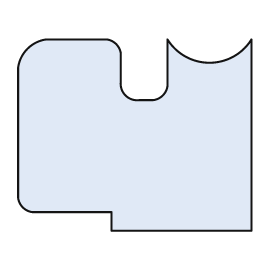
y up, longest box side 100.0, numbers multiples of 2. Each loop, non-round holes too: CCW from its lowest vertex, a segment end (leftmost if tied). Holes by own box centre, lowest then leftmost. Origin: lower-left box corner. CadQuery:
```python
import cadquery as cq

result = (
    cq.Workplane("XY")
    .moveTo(40.0, 0.0)
    .lineTo(100.0, 0.0)
    .lineTo(100.0, 82.0)
    .threePointArc((82.0, 72.0), (64.0, 82.0))
    .lineTo(64.0, 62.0)
    .threePointArc((62.0, 58.0), (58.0, 56.0))
    .lineTo(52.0, 56.0)
    .threePointArc((46.0, 58.0), (44.0, 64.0))
    .lineTo(44.0, 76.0)
    .threePointArc((42.0, 80.0), (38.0, 82.0))
    .lineTo(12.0, 82.0)
    .threePointArc((4.0, 78.0), (0.0, 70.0))
    .lineTo(0.0, 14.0)
    .threePointArc((2.0, 10.0), (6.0, 8.0))
    .lineTo(40.0, 8.0)
    .close()
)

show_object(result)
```